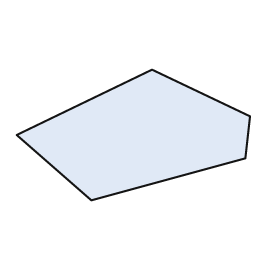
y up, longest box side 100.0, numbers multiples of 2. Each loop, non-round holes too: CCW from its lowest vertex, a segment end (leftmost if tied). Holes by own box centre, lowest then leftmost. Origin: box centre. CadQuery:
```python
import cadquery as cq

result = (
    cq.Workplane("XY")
    .moveTo(-18.0, -28.0)
    .lineTo(48.0, -10.0)
    .lineTo(50.0, 8.0)
    .lineTo(8.0, 28.0)
    .lineTo(-50.0, 0.0)
    .close()
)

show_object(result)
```